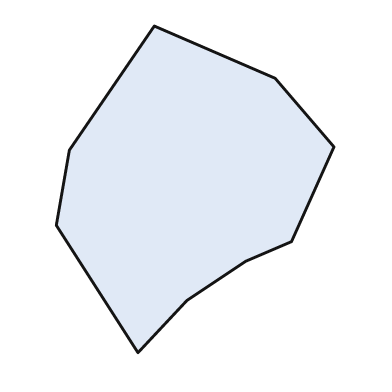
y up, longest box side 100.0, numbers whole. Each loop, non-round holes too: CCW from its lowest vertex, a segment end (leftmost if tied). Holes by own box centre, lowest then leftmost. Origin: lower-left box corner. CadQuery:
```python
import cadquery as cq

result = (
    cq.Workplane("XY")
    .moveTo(25.0, 0.0)
    .lineTo(40.0, 16.0)
    .lineTo(58.0, 28.0)
    .lineTo(72.0, 34.0)
    .lineTo(85.0, 63.0)
    .lineTo(67.0, 84.0)
    .lineTo(30.0, 100.0)
    .lineTo(4.0, 62.0)
    .lineTo(0.0, 39.0)
    .close()
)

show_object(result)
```